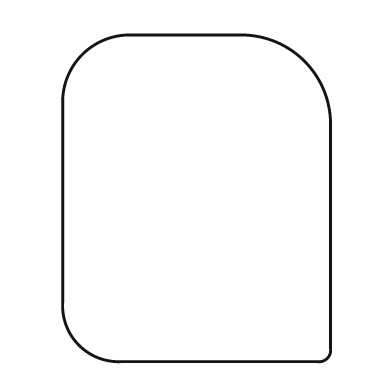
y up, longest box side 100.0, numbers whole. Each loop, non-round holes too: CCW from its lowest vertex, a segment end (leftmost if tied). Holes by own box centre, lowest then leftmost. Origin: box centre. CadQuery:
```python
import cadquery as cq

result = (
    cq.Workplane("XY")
    .moveTo(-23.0, -50.0)
    .lineTo(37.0, -50.0)
    .threePointArc((40.0, -49.0), (41.0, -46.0))
    .lineTo(41.0, 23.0)
    .threePointArc((33.0, 42.0), (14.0, 50.0))
    .lineTo(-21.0, 50.0)
    .threePointArc((-35.0, 44.0), (-41.0, 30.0))
    .lineTo(-41.0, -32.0)
    .threePointArc((-36.0, -45.0), (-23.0, -50.0))
    .close()
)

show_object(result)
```